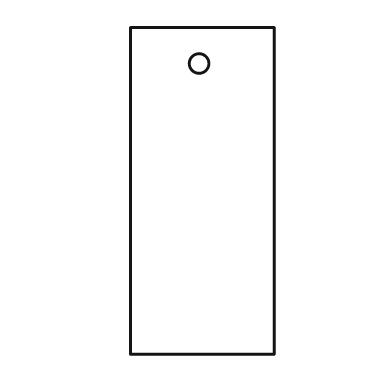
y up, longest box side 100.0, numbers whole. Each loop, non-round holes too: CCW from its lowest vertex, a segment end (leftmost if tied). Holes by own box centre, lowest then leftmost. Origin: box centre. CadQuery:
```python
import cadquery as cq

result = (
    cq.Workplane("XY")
    .moveTo(-22.0, -50.0)
    .lineTo(22.0, -50.0)
    .lineTo(22.0, 50.0)
    .lineTo(-22.0, 50.0)
    .close()
    .moveTo(-1.0, 39.0)
    .circle(3.0)
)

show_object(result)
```